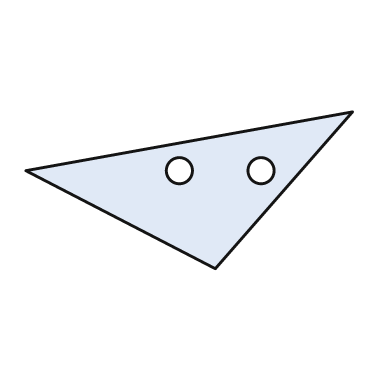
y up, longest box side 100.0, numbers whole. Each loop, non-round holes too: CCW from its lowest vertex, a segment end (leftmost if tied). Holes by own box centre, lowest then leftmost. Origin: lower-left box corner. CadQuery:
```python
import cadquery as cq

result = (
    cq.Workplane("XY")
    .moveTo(58.0, 0.0)
    .lineTo(100.0, 48.0)
    .lineTo(0.0, 30.0)
    .close()
    .moveTo(47.0, 30.0)
    .circle(4.0)
    .moveTo(72.0, 30.0)
    .circle(4.0)
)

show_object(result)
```